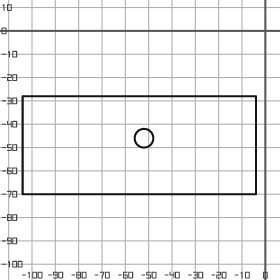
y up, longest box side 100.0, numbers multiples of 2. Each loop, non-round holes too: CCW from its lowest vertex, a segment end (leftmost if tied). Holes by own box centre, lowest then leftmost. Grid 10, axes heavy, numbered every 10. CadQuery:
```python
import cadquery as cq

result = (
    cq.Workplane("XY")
    .moveTo(-104.0, -70.0)
    .lineTo(-4.0, -70.0)
    .lineTo(-4.0, -28.0)
    .lineTo(-104.0, -28.0)
    .close()
    .moveTo(-52.0, -46.0)
    .circle(4.0)
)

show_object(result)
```